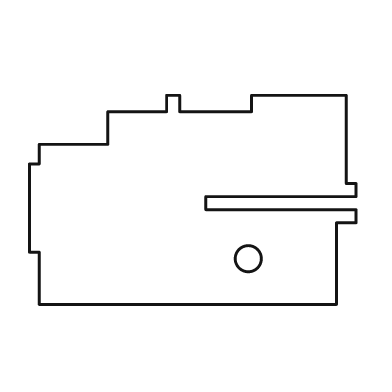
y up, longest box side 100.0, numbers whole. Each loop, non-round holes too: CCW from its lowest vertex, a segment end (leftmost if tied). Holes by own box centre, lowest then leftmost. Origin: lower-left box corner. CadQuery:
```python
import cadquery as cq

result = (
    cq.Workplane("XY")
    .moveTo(3.0, 0.0)
    .lineTo(94.0, 0.0)
    .lineTo(94.0, 25.0)
    .lineTo(100.0, 25.0)
    .lineTo(100.0, 29.0)
    .lineTo(54.0, 29.0)
    .lineTo(54.0, 33.0)
    .lineTo(100.0, 33.0)
    .lineTo(100.0, 37.0)
    .lineTo(97.0, 37.0)
    .lineTo(97.0, 64.0)
    .lineTo(68.0, 64.0)
    .lineTo(68.0, 59.0)
    .lineTo(46.0, 59.0)
    .lineTo(46.0, 64.0)
    .lineTo(42.0, 64.0)
    .lineTo(42.0, 59.0)
    .lineTo(24.0, 59.0)
    .lineTo(24.0, 49.0)
    .lineTo(3.0, 49.0)
    .lineTo(3.0, 43.0)
    .lineTo(0.0, 43.0)
    .lineTo(0.0, 16.0)
    .lineTo(3.0, 16.0)
    .close()
    .moveTo(67.0, 14.0)
    .circle(4.0)
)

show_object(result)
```